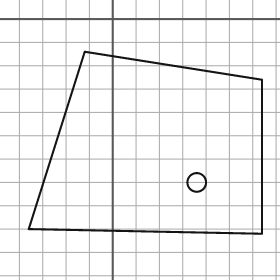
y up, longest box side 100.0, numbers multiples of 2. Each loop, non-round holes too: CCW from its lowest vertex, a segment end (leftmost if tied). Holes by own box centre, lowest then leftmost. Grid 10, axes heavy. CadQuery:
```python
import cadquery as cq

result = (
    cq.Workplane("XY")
    .moveTo(64.0, -92.0)
    .lineTo(64.0, -26.0)
    .lineTo(-12.0, -14.0)
    .lineTo(-36.0, -90.0)
    .close()
    .moveTo(36.0, -70.0)
    .circle(4.0)
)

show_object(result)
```